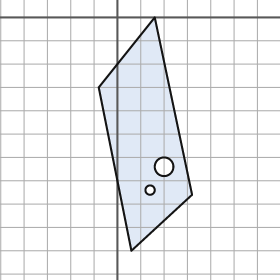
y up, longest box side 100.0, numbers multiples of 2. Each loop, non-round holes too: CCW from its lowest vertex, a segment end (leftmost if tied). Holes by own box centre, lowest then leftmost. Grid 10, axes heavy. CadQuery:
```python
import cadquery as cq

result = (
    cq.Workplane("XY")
    .moveTo(6.0, -100.0)
    .lineTo(32.0, -76.0)
    .lineTo(16.0, 0.0)
    .lineTo(-8.0, -30.0)
    .close()
    .moveTo(14.0, -74.0)
    .circle(2.0)
    .moveTo(20.0, -64.0)
    .circle(4.0)
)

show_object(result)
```